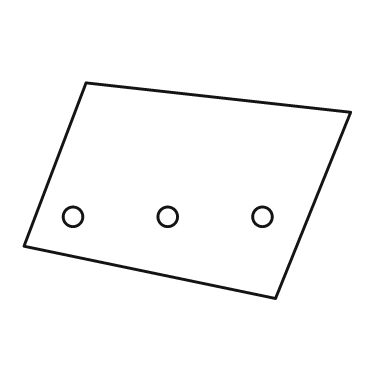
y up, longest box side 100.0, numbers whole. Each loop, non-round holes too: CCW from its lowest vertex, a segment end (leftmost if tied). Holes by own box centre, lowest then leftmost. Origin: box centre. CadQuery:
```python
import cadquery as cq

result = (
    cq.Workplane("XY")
    .moveTo(27.0, -33.0)
    .lineTo(50.0, 24.0)
    .lineTo(-31.0, 33.0)
    .lineTo(-50.0, -17.0)
    .close()
    .moveTo(-35.0, -8.0)
    .circle(3.0)
    .moveTo(-6.0, -8.0)
    .circle(3.0)
    .moveTo(23.0, -8.0)
    .circle(3.0)
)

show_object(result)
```